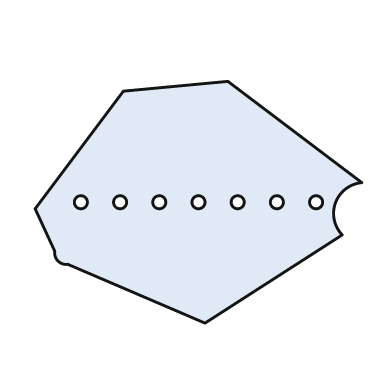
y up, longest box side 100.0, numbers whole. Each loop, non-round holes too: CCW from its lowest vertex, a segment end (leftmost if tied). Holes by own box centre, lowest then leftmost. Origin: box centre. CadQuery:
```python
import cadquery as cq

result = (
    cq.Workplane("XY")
    .moveTo(2.0, -37.0)
    .lineTo(44.0, -10.0)
    .threePointArc((42.0, 0.0), (50.0, 6.0))
    .lineTo(9.0, 37.0)
    .lineTo(-23.0, 34.0)
    .lineTo(-50.0, -2.0)
    .lineTo(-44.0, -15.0)
    .threePointArc((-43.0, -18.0), (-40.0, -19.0))
    .close()
    .moveTo(-36.0, 0.0)
    .circle(2.0)
    .moveTo(-24.0, 0.0)
    .circle(2.0)
    .moveTo(-12.0, 0.0)
    .circle(2.0)
    .moveTo(0.0, 0.0)
    .circle(2.0)
    .moveTo(12.0, 0.0)
    .circle(2.0)
    .moveTo(24.0, 0.0)
    .circle(2.0)
    .moveTo(36.0, 0.0)
    .circle(2.0)
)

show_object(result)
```